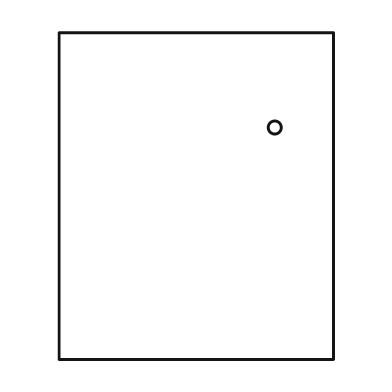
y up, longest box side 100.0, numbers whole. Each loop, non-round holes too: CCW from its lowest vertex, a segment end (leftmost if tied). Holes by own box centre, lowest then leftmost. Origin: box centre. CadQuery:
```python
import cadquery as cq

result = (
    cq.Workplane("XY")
    .moveTo(-42.0, -50.0)
    .lineTo(42.0, -50.0)
    .lineTo(42.0, 50.0)
    .lineTo(-42.0, 50.0)
    .close()
    .moveTo(24.0, 21.0)
    .circle(2.0)
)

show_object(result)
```